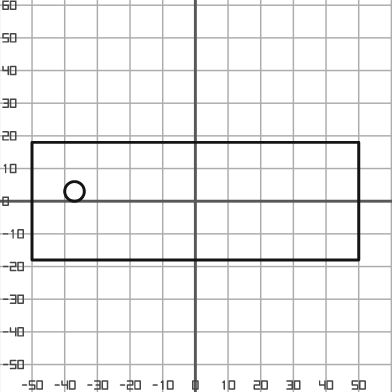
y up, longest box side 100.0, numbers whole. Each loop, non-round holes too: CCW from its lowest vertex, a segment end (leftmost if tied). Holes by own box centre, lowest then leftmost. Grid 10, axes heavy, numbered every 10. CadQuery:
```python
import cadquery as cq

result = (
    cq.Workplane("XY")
    .moveTo(-50.0, -18.0)
    .lineTo(50.0, -18.0)
    .lineTo(50.0, 18.0)
    .lineTo(-50.0, 18.0)
    .close()
    .moveTo(-37.0, 3.0)
    .circle(3.0)
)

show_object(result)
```